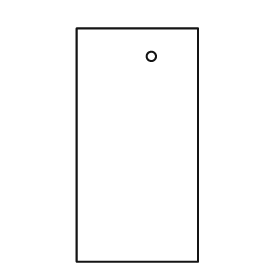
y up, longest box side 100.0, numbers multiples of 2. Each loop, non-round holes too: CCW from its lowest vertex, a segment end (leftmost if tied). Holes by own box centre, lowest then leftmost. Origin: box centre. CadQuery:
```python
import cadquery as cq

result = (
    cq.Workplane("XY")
    .moveTo(-26.0, -50.0)
    .lineTo(26.0, -50.0)
    .lineTo(26.0, 50.0)
    .lineTo(-26.0, 50.0)
    .close()
    .moveTo(6.0, 38.0)
    .circle(2.0)
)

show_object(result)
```